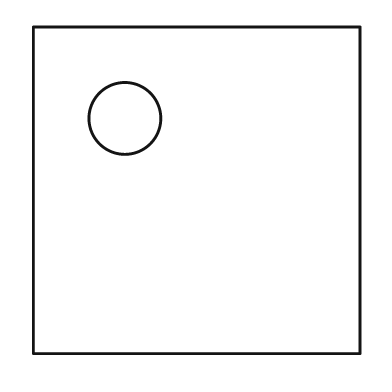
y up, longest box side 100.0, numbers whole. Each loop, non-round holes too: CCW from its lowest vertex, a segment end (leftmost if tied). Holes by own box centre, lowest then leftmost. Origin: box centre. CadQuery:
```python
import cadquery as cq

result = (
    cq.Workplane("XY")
    .moveTo(-50.0, -50.0)
    .lineTo(50.0, -50.0)
    .lineTo(50.0, 50.0)
    .lineTo(-50.0, 50.0)
    .close()
    .moveTo(-22.0, 22.0)
    .circle(11.0)
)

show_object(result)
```